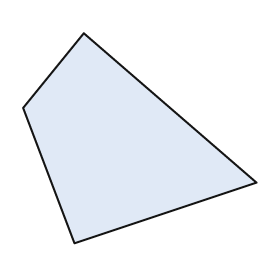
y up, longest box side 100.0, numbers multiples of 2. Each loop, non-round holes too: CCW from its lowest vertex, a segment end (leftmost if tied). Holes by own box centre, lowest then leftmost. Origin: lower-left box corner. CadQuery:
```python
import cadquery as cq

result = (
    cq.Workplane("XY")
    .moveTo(22.0, 0.0)
    .lineTo(100.0, 26.0)
    .lineTo(26.0, 90.0)
    .lineTo(0.0, 58.0)
    .close()
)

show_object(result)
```